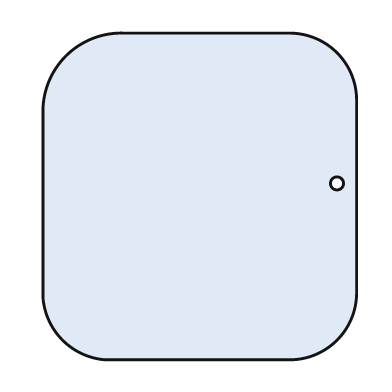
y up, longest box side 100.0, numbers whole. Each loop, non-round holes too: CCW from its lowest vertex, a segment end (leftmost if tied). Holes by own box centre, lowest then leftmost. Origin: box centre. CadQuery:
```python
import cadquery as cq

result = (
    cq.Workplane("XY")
    .moveTo(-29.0, -50.0)
    .lineTo(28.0, -50.0)
    .threePointArc((42.0, -44.0), (48.0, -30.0))
    .lineTo(48.0, 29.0)
    .threePointArc((42.0, 44.0), (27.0, 50.0))
    .lineTo(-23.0, 50.0)
    .threePointArc((-41.0, 43.0), (-48.0, 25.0))
    .lineTo(-48.0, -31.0)
    .threePointArc((-42.0, -44.0), (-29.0, -50.0))
    .close()
    .moveTo(42.0, 4.0)
    .circle(2.0)
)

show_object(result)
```